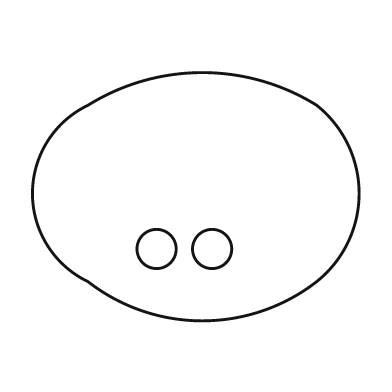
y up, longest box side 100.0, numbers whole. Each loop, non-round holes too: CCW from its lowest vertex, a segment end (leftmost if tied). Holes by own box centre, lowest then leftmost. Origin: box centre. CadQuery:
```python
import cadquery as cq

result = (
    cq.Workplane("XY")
    .moveTo(-33.0, -26.0)
    .threePointArc((2.0, -38.0), (37.0, -26.0))
    .threePointArc((50.0, 1.0), (37.0, 28.0))
    .threePointArc((2.0, 38.0), (-33.0, 28.0))
    .threePointArc((-50.0, 1.0), (-33.0, -26.0))
    .close()
    .moveTo(-12.0, -16.0)
    .circle(6.0)
    .moveTo(5.0, -16.0)
    .circle(6.0)
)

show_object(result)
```